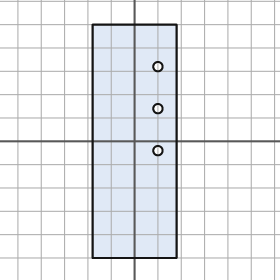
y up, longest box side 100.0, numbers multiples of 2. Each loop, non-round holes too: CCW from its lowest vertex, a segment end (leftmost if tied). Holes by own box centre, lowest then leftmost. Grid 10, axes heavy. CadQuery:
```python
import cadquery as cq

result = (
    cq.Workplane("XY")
    .moveTo(-18.0, -50.0)
    .lineTo(18.0, -50.0)
    .lineTo(18.0, 50.0)
    .lineTo(-18.0, 50.0)
    .close()
    .moveTo(10.0, -4.0)
    .circle(2.0)
    .moveTo(10.0, 14.0)
    .circle(2.0)
    .moveTo(10.0, 32.0)
    .circle(2.0)
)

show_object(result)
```